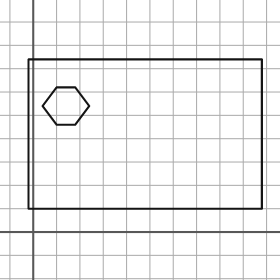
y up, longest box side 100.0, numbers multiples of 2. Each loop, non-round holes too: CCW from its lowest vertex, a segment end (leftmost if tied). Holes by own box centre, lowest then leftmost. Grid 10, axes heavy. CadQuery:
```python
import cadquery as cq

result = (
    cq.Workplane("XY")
    .moveTo(-2.0, 10.0)
    .lineTo(98.0, 10.0)
    .lineTo(98.0, 74.0)
    .lineTo(-2.0, 74.0)
    .close()
    .moveTo(10.0, 46.0)
    .lineTo(18.0, 46.0)
    .lineTo(24.0, 54.0)
    .lineTo(18.0, 62.0)
    .lineTo(10.0, 62.0)
    .lineTo(4.0, 54.0)
    .close()
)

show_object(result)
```